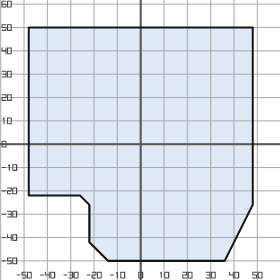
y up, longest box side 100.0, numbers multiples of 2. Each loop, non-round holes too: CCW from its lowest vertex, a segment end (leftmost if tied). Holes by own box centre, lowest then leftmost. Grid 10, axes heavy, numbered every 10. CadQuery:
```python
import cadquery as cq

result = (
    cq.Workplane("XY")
    .moveTo(-14.0, -50.0)
    .lineTo(36.0, -50.0)
    .lineTo(48.0, -26.0)
    .lineTo(48.0, 50.0)
    .lineTo(-48.0, 50.0)
    .lineTo(-48.0, -22.0)
    .lineTo(-26.0, -22.0)
    .lineTo(-22.0, -26.0)
    .lineTo(-22.0, -42.0)
    .close()
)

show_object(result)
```